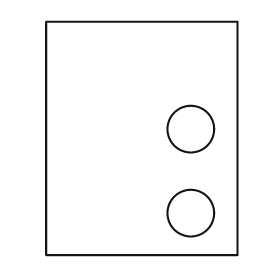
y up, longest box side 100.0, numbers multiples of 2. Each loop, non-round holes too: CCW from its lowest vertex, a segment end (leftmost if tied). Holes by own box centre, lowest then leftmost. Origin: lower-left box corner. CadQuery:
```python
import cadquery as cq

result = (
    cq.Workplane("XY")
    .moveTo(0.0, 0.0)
    .lineTo(82.0, 0.0)
    .lineTo(82.0, 100.0)
    .lineTo(0.0, 100.0)
    .close()
    .moveTo(62.0, 18.0)
    .circle(10.0)
    .moveTo(62.0, 54.0)
    .circle(10.0)
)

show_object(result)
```